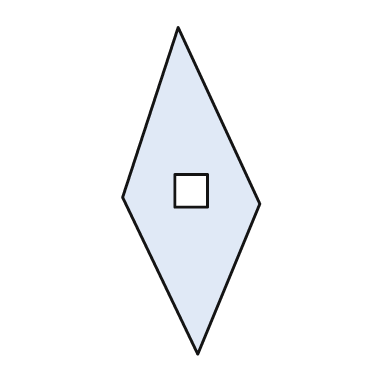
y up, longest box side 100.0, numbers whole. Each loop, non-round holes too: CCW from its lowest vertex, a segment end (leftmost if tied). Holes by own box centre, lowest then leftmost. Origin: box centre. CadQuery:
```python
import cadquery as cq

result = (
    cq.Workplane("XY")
    .moveTo(2.0, -50.0)
    .lineTo(21.0, -4.0)
    .lineTo(-4.0, 50.0)
    .lineTo(-21.0, -2.0)
    .close()
    .moveTo(-5.0, -5.0)
    .lineTo(5.0, -5.0)
    .lineTo(5.0, 5.0)
    .lineTo(-5.0, 5.0)
    .close()
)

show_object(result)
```